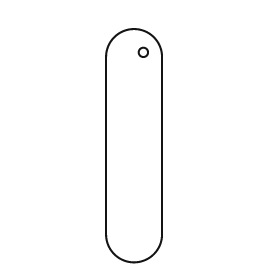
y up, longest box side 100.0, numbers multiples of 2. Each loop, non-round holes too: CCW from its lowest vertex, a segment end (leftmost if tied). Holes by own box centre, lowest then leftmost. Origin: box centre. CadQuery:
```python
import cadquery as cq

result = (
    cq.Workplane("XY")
    .moveTo(-12.0, -38.0)
    .threePointArc((0.0, -50.0), (12.0, -38.0))
    .lineTo(12.0, 38.0)
    .threePointArc((0.0, 50.0), (-12.0, 38.0))
    .close()
    .moveTo(4.0, 40.0)
    .circle(2.0)
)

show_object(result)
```